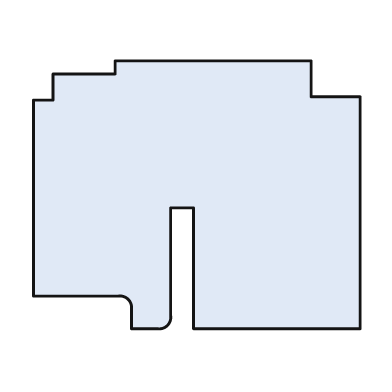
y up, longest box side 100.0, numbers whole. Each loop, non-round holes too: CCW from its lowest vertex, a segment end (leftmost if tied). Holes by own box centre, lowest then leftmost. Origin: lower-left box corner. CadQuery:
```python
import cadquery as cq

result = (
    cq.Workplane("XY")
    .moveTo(30.0, 0.0)
    .lineTo(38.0, 0.0)
    .threePointArc((41.0, 1.0), (42.0, 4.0))
    .lineTo(42.0, 37.0)
    .lineTo(49.0, 37.0)
    .lineTo(49.0, 0.0)
    .lineTo(100.0, 0.0)
    .lineTo(100.0, 71.0)
    .lineTo(85.0, 71.0)
    .lineTo(85.0, 82.0)
    .lineTo(25.0, 82.0)
    .lineTo(25.0, 78.0)
    .lineTo(6.0, 78.0)
    .lineTo(6.0, 70.0)
    .lineTo(0.0, 70.0)
    .lineTo(0.0, 10.0)
    .lineTo(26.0, 10.0)
    .threePointArc((29.0, 9.0), (30.0, 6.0))
    .close()
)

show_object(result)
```